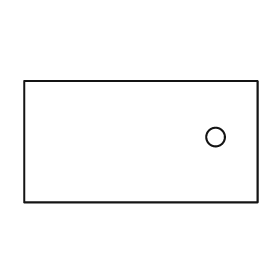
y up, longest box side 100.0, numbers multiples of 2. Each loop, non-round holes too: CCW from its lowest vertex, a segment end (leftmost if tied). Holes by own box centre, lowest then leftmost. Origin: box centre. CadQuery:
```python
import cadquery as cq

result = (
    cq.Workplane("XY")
    .moveTo(-50.0, -26.0)
    .lineTo(50.0, -26.0)
    .lineTo(50.0, 26.0)
    .lineTo(-50.0, 26.0)
    .close()
    .moveTo(32.0, 2.0)
    .circle(4.0)
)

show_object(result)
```